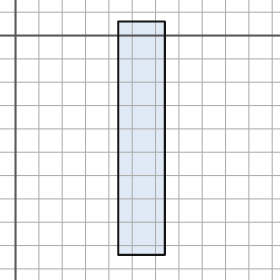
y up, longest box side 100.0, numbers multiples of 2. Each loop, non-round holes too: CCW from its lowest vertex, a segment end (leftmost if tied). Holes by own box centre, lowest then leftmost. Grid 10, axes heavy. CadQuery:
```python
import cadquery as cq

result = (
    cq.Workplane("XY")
    .moveTo(44.0, -94.0)
    .lineTo(64.0, -94.0)
    .lineTo(64.0, 6.0)
    .lineTo(44.0, 6.0)
    .close()
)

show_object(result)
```